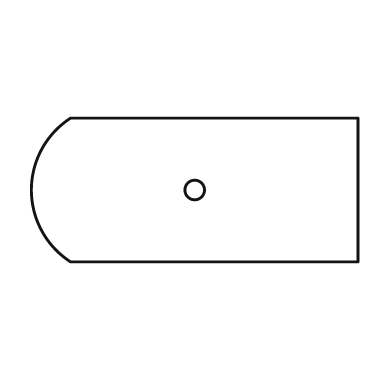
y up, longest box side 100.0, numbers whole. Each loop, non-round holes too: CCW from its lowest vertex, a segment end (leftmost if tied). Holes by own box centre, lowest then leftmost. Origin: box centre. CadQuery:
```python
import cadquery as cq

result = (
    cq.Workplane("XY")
    .moveTo(-38.0, -22.0)
    .lineTo(50.0, -22.0)
    .lineTo(50.0, 22.0)
    .lineTo(-38.0, 22.0)
    .threePointArc((-50.0, 0.0), (-38.0, -22.0))
    .close()
    .moveTo(0.0, 0.0)
    .circle(3.0)
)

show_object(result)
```